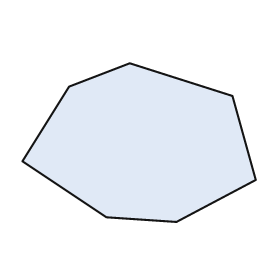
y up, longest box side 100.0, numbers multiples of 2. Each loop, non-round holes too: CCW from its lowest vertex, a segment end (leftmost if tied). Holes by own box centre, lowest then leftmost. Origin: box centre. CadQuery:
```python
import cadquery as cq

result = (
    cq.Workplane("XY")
    .moveTo(16.0, -34.0)
    .lineTo(50.0, -16.0)
    .lineTo(40.0, 20.0)
    .lineTo(-4.0, 34.0)
    .lineTo(-30.0, 24.0)
    .lineTo(-50.0, -8.0)
    .lineTo(-14.0, -32.0)
    .close()
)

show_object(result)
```